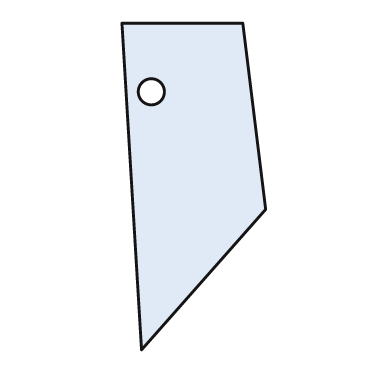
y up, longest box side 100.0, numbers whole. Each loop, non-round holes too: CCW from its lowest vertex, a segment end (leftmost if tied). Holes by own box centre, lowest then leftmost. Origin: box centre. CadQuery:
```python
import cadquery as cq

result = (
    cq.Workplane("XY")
    .moveTo(-16.0, -50.0)
    .lineTo(22.0, -7.0)
    .lineTo(15.0, 50.0)
    .lineTo(-22.0, 50.0)
    .close()
    .moveTo(-13.0, 29.0)
    .circle(4.0)
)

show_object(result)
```